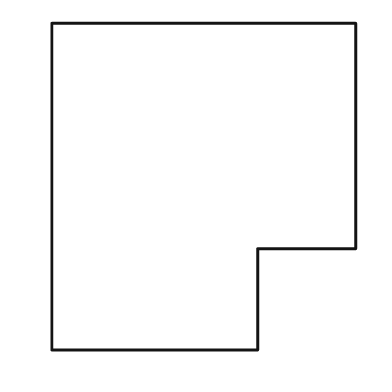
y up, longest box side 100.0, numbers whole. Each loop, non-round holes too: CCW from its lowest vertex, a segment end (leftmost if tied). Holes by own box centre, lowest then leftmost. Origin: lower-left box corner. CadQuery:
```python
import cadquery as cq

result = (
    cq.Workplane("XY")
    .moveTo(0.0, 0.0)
    .lineTo(63.0, 0.0)
    .lineTo(63.0, 31.0)
    .lineTo(93.0, 31.0)
    .lineTo(93.0, 100.0)
    .lineTo(0.0, 100.0)
    .close()
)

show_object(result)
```